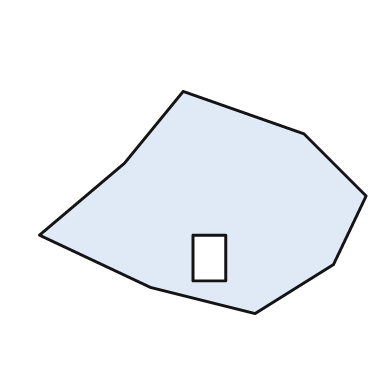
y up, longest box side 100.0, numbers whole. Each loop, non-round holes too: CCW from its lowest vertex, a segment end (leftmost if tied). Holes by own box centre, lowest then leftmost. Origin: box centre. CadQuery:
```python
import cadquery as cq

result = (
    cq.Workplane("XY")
    .moveTo(16.0, -34.0)
    .lineTo(40.0, -19.0)
    .lineTo(50.0, 2.0)
    .lineTo(31.0, 21.0)
    .lineTo(-6.0, 34.0)
    .lineTo(-24.0, 12.0)
    .lineTo(-50.0, -10.0)
    .lineTo(-16.0, -26.0)
    .close()
    .moveTo(-3.0, -24.0)
    .lineTo(7.0, -24.0)
    .lineTo(7.0, -10.0)
    .lineTo(-3.0, -10.0)
    .close()
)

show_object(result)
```